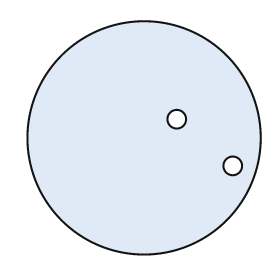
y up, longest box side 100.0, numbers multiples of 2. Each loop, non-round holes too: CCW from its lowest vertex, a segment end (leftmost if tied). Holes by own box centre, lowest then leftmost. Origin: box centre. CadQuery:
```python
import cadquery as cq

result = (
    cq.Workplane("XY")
    .moveTo(0.0, 0.0)
    .circle(50.0)
    .moveTo(38.0, -12.0)
    .circle(4.0)
    .moveTo(14.0, 8.0)
    .circle(4.0)
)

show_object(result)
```